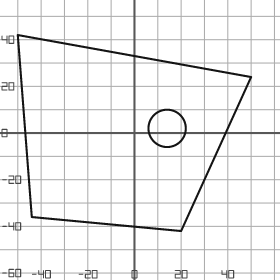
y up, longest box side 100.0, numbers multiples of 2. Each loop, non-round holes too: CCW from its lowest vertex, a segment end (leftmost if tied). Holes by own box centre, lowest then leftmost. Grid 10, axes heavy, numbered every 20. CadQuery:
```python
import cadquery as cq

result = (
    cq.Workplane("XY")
    .moveTo(20.0, -42.0)
    .lineTo(50.0, 24.0)
    .lineTo(-50.0, 42.0)
    .lineTo(-44.0, -36.0)
    .close()
    .moveTo(14.0, 2.0)
    .circle(8.0)
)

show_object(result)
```